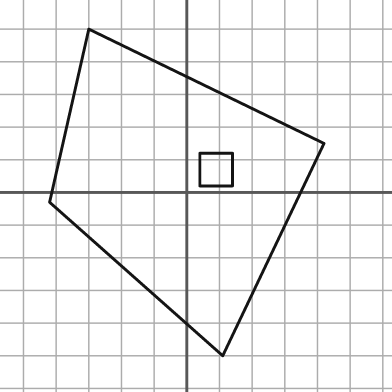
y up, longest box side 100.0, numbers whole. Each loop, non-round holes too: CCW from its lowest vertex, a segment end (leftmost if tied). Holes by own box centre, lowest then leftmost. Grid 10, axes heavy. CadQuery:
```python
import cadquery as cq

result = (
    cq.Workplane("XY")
    .moveTo(11.0, -50.0)
    .lineTo(42.0, 15.0)
    .lineTo(-30.0, 50.0)
    .lineTo(-42.0, -3.0)
    .close()
    .moveTo(4.0, 2.0)
    .lineTo(14.0, 2.0)
    .lineTo(14.0, 12.0)
    .lineTo(4.0, 12.0)
    .close()
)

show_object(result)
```